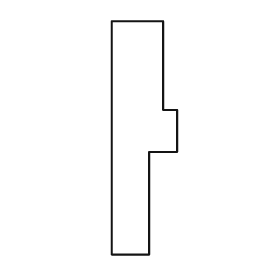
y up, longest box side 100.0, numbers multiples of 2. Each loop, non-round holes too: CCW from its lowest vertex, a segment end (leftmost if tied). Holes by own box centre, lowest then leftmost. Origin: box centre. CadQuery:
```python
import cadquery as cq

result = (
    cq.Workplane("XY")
    .moveTo(-14.0, -50.0)
    .lineTo(2.0, -50.0)
    .lineTo(2.0, -6.0)
    .lineTo(14.0, -6.0)
    .lineTo(14.0, 12.0)
    .lineTo(8.0, 12.0)
    .lineTo(8.0, 50.0)
    .lineTo(-14.0, 50.0)
    .close()
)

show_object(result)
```